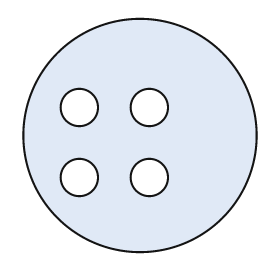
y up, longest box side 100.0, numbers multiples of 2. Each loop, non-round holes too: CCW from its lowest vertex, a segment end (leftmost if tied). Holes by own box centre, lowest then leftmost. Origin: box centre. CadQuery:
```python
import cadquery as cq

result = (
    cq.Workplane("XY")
    .moveTo(0.0, 0.0)
    .circle(50.0)
    .moveTo(-26.0, -18.0)
    .circle(8.0)
    .moveTo(4.0, -18.0)
    .circle(8.0)
    .moveTo(-26.0, 12.0)
    .circle(8.0)
    .moveTo(4.0, 12.0)
    .circle(8.0)
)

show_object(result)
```